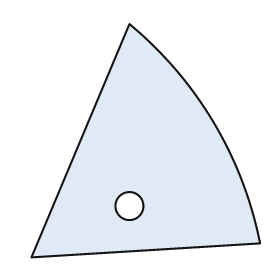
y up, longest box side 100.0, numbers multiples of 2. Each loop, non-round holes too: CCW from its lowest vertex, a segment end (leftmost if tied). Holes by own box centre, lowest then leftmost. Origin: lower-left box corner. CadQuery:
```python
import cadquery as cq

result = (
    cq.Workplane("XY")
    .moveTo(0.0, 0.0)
    .lineTo(98.0, 6.0)
    .threePointArc((78.0, 58.0), (42.0, 100.0))
    .close()
    .moveTo(42.0, 22.0)
    .circle(6.0)
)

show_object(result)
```